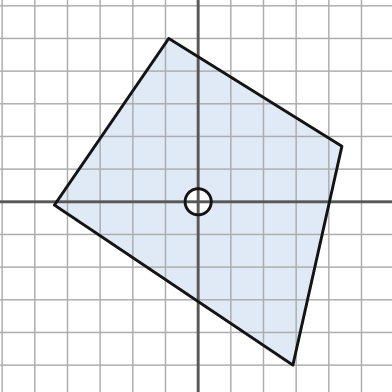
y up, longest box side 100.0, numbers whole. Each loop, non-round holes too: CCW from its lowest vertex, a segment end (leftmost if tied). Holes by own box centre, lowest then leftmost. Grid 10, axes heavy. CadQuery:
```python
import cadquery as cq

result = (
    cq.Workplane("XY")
    .moveTo(29.0, -50.0)
    .lineTo(44.0, 17.0)
    .lineTo(-9.0, 50.0)
    .lineTo(-44.0, -1.0)
    .close()
    .moveTo(0.0, 0.0)
    .circle(4.0)
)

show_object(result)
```